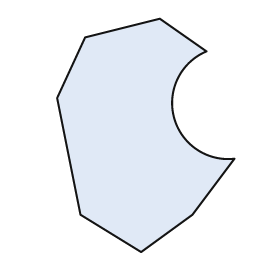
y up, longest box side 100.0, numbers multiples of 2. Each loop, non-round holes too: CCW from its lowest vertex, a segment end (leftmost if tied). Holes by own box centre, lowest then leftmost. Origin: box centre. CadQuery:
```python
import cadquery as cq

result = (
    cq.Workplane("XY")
    .moveTo(-2.0, -50.0)
    .lineTo(20.0, -34.0)
    .lineTo(38.0, -10.0)
    .threePointArc((12.0, 8.0), (26.0, 36.0))
    .lineTo(6.0, 50.0)
    .lineTo(-26.0, 42.0)
    .lineTo(-38.0, 16.0)
    .lineTo(-28.0, -34.0)
    .close()
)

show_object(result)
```